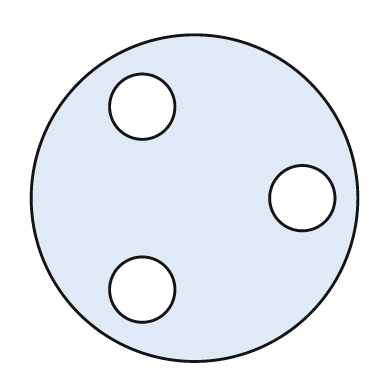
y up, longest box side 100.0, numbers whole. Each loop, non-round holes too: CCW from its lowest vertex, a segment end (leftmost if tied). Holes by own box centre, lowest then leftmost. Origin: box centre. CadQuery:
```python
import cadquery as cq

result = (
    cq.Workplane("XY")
    .moveTo(0.0, 0.0)
    .circle(50.0)
    .moveTo(-16.0, -28.0)
    .circle(10.0)
    .moveTo(33.0, 0.0)
    .circle(10.0)
    .moveTo(-16.0, 28.0)
    .circle(10.0)
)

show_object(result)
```